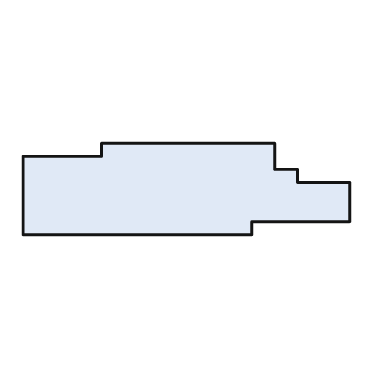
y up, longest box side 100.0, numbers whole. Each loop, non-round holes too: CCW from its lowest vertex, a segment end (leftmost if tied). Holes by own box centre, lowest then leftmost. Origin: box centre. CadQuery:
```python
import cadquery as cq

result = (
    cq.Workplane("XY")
    .moveTo(-50.0, -14.0)
    .lineTo(20.0, -14.0)
    .lineTo(20.0, -10.0)
    .lineTo(50.0, -10.0)
    .lineTo(50.0, 2.0)
    .lineTo(34.0, 2.0)
    .lineTo(34.0, 6.0)
    .lineTo(27.0, 6.0)
    .lineTo(27.0, 14.0)
    .lineTo(-26.0, 14.0)
    .lineTo(-26.0, 10.0)
    .lineTo(-50.0, 10.0)
    .close()
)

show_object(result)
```